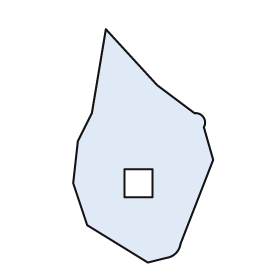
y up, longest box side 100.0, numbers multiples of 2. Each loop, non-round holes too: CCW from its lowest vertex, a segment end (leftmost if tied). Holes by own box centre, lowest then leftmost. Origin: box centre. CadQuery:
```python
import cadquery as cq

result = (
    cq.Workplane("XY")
    .moveTo(2.0, -50.0)
    .lineTo(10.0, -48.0)
    .threePointArc((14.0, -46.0), (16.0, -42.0))
    .lineTo(30.0, -6.0)
    .lineTo(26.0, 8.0)
    .threePointArc((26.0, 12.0), (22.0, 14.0))
    .lineTo(6.0, 26.0)
    .lineTo(-16.0, 50.0)
    .lineTo(-22.0, 14.0)
    .lineTo(-28.0, 2.0)
    .lineTo(-30.0, -16.0)
    .lineTo(-24.0, -34.0)
    .close()
    .moveTo(-8.0, -22.0)
    .lineTo(4.0, -22.0)
    .lineTo(4.0, -10.0)
    .lineTo(-8.0, -10.0)
    .close()
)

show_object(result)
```